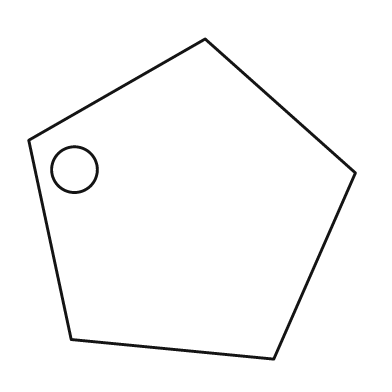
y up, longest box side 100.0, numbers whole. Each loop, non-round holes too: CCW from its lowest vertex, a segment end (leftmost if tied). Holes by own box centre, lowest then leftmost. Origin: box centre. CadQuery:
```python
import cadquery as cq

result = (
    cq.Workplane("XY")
    .moveTo(25.0, -49.0)
    .lineTo(50.0, 8.0)
    .lineTo(4.0, 49.0)
    .lineTo(-50.0, 18.0)
    .lineTo(-37.0, -43.0)
    .close()
    .moveTo(-36.0, 9.0)
    .circle(7.0)
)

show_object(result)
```